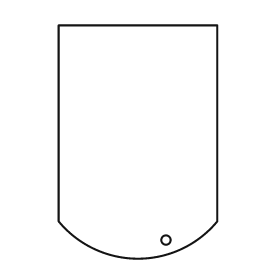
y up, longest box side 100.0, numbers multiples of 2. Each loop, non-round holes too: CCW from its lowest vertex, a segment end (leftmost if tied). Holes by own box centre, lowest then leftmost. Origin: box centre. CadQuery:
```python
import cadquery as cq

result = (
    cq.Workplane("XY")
    .moveTo(-34.0, -34.0)
    .threePointArc((0.0, -50.0), (34.0, -34.0))
    .lineTo(34.0, 50.0)
    .lineTo(-34.0, 50.0)
    .close()
    .moveTo(12.0, -42.0)
    .circle(2.0)
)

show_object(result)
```